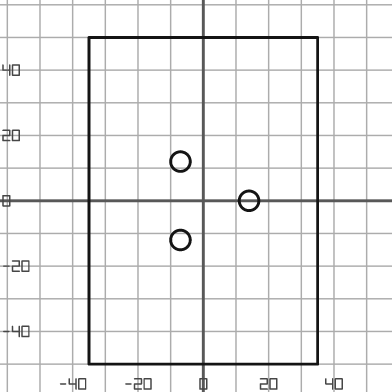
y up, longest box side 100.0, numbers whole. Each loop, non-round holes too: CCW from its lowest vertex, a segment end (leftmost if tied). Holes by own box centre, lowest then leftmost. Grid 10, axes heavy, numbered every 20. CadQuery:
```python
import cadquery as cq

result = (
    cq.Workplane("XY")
    .moveTo(-35.0, -50.0)
    .lineTo(35.0, -50.0)
    .lineTo(35.0, 50.0)
    .lineTo(-35.0, 50.0)
    .close()
    .moveTo(-7.0, -12.0)
    .circle(3.0)
    .moveTo(14.0, 0.0)
    .circle(3.0)
    .moveTo(-7.0, 12.0)
    .circle(3.0)
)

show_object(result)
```